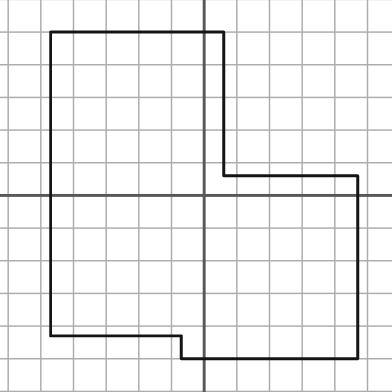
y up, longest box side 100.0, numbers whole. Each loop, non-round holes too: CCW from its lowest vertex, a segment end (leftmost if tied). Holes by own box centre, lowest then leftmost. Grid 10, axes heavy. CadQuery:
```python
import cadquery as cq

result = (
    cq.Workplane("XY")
    .moveTo(-7.0, -50.0)
    .lineTo(47.0, -50.0)
    .lineTo(47.0, 6.0)
    .lineTo(6.0, 6.0)
    .lineTo(6.0, 50.0)
    .lineTo(-47.0, 50.0)
    .lineTo(-47.0, -43.0)
    .lineTo(-7.0, -43.0)
    .close()
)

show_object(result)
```